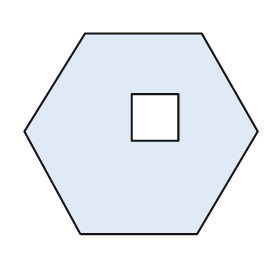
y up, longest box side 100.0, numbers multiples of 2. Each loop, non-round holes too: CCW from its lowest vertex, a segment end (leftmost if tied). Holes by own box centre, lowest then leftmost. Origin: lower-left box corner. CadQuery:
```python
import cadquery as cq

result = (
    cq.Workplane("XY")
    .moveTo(24.0, 0.0)
    .lineTo(74.0, 0.0)
    .lineTo(100.0, 44.0)
    .lineTo(76.0, 86.0)
    .lineTo(26.0, 86.0)
    .lineTo(0.0, 44.0)
    .close()
    .moveTo(46.0, 40.0)
    .lineTo(66.0, 40.0)
    .lineTo(66.0, 60.0)
    .lineTo(46.0, 60.0)
    .close()
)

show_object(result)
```